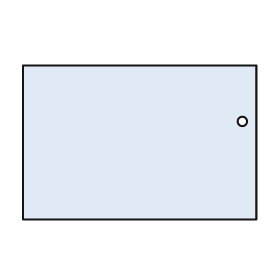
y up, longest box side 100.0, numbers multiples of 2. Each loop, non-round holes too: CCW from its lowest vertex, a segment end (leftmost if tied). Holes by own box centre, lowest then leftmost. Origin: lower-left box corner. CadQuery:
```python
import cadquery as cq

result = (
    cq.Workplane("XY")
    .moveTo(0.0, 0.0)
    .lineTo(100.0, 0.0)
    .lineTo(100.0, 66.0)
    .lineTo(0.0, 66.0)
    .close()
    .moveTo(94.0, 42.0)
    .circle(2.0)
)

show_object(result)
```